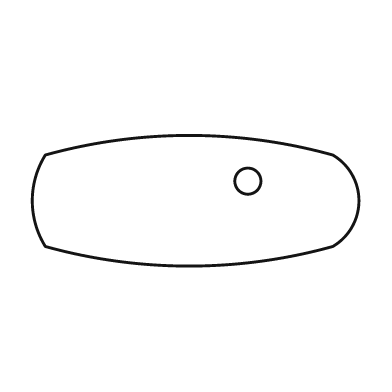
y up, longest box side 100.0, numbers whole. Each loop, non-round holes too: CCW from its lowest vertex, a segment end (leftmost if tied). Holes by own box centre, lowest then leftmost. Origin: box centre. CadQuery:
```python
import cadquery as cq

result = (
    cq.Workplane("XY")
    .moveTo(-46.0, -14.0)
    .threePointArc((-2.0, -20.0), (42.0, -14.0))
    .threePointArc((50.0, 0.0), (42.0, 14.0))
    .threePointArc((-2.0, 20.0), (-46.0, 14.0))
    .threePointArc((-50.0, 0.0), (-46.0, -14.0))
    .close()
    .moveTo(16.0, 6.0)
    .circle(4.0)
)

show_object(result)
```